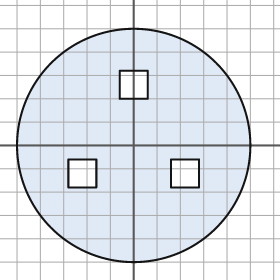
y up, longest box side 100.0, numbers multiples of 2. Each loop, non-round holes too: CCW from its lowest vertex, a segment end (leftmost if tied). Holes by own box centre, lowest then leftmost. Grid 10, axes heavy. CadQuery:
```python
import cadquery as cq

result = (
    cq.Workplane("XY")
    .moveTo(0.0, 0.0)
    .circle(50.0)
    .moveTo(-28.0, -18.0)
    .lineTo(-16.0, -18.0)
    .lineTo(-16.0, -6.0)
    .lineTo(-28.0, -6.0)
    .close()
    .moveTo(16.0, -18.0)
    .lineTo(28.0, -18.0)
    .lineTo(28.0, -6.0)
    .lineTo(16.0, -6.0)
    .close()
    .moveTo(-6.0, 20.0)
    .lineTo(6.0, 20.0)
    .lineTo(6.0, 32.0)
    .lineTo(-6.0, 32.0)
    .close()
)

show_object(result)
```